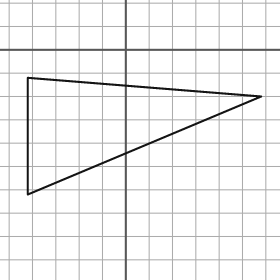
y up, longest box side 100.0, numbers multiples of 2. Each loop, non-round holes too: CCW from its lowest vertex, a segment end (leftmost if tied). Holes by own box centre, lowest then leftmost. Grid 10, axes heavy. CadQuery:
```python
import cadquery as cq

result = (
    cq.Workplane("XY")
    .moveTo(-42.0, -62.0)
    .lineTo(58.0, -20.0)
    .lineTo(-42.0, -12.0)
    .close()
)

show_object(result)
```